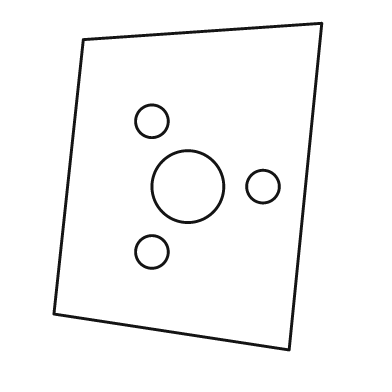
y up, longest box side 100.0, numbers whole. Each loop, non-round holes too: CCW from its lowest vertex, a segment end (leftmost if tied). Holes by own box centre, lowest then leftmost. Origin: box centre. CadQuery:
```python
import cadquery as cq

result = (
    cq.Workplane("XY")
    .moveTo(31.0, -50.0)
    .lineTo(41.0, 50.0)
    .lineTo(-32.0, 45.0)
    .lineTo(-41.0, -39.0)
    .close()
    .moveTo(-11.0, -20.0)
    .circle(5.0)
    .moveTo(0.0, 0.0)
    .circle(11.0)
    .moveTo(23.0, 0.0)
    .circle(5.0)
    .moveTo(-11.0, 20.0)
    .circle(5.0)
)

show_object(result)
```